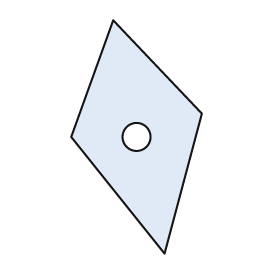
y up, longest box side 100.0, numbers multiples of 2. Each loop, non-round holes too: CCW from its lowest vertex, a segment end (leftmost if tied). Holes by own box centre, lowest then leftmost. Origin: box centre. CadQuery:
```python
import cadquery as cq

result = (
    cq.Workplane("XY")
    .moveTo(12.0, -50.0)
    .lineTo(28.0, 10.0)
    .lineTo(-10.0, 50.0)
    .lineTo(-28.0, 0.0)
    .close()
    .moveTo(0.0, 0.0)
    .circle(6.0)
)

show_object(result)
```